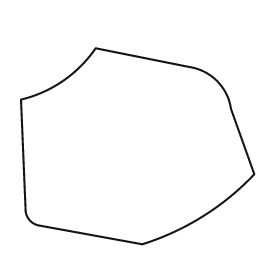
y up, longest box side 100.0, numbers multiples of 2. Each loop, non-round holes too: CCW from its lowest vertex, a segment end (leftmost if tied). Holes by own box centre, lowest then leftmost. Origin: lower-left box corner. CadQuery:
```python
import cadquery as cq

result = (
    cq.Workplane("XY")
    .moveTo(52.0, 0.0)
    .threePointArc((78.0, 12.0), (100.0, 30.0))
    .lineTo(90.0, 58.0)
    .threePointArc((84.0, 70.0), (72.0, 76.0))
    .lineTo(32.0, 84.0)
    .threePointArc((18.0, 70.0), (0.0, 62.0))
    .lineTo(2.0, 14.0)
    .threePointArc((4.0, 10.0), (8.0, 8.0))
    .close()
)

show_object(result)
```